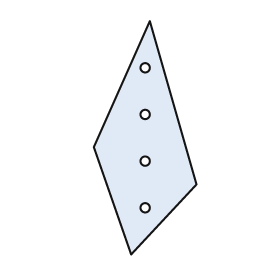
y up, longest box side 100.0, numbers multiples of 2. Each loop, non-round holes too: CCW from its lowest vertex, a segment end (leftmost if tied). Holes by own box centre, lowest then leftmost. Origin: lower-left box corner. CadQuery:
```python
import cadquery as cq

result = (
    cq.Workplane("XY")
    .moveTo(16.0, 0.0)
    .lineTo(44.0, 30.0)
    .lineTo(24.0, 100.0)
    .lineTo(0.0, 46.0)
    .close()
    .moveTo(22.0, 20.0)
    .circle(2.0)
    .moveTo(22.0, 40.0)
    .circle(2.0)
    .moveTo(22.0, 60.0)
    .circle(2.0)
    .moveTo(22.0, 80.0)
    .circle(2.0)
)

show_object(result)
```